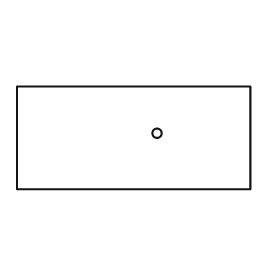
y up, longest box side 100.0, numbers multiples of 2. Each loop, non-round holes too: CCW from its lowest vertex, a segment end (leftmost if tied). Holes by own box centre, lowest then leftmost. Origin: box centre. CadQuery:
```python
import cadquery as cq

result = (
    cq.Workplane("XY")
    .moveTo(-50.0, -22.0)
    .lineTo(50.0, -22.0)
    .lineTo(50.0, 22.0)
    .lineTo(-50.0, 22.0)
    .close()
    .moveTo(10.0, 2.0)
    .circle(2.0)
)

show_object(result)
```